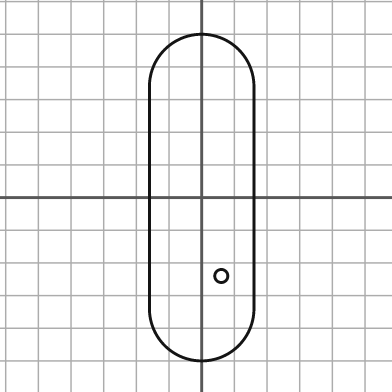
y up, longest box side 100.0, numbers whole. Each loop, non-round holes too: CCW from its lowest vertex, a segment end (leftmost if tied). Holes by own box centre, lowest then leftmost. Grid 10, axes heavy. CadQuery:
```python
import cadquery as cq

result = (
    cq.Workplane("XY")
    .moveTo(-16.0, -34.0)
    .threePointArc((0.0, -50.0), (16.0, -34.0))
    .lineTo(16.0, 34.0)
    .threePointArc((0.0, 50.0), (-16.0, 34.0))
    .close()
    .moveTo(6.0, -24.0)
    .circle(2.0)
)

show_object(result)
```